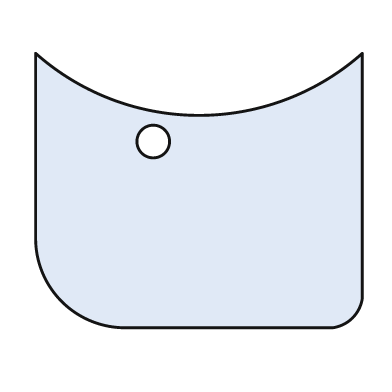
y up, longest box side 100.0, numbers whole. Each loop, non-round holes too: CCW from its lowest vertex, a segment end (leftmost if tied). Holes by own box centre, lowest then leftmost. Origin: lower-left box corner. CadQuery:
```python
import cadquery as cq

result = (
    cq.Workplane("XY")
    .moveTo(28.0, 0.0)
    .lineTo(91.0, 0.0)
    .threePointArc((97.0, 3.0), (100.0, 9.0))
    .lineTo(100.0, 84.0)
    .threePointArc((50.0, 65.0), (0.0, 84.0))
    .lineTo(0.0, 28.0)
    .threePointArc((8.0, 8.0), (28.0, 0.0))
    .close()
    .moveTo(36.0, 57.0)
    .circle(5.0)
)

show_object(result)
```